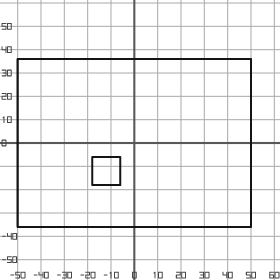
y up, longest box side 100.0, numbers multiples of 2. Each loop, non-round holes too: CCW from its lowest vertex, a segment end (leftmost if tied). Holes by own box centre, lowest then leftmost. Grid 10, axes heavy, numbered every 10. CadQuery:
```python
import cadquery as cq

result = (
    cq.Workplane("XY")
    .moveTo(-50.0, -36.0)
    .lineTo(50.0, -36.0)
    .lineTo(50.0, 36.0)
    .lineTo(-50.0, 36.0)
    .close()
    .moveTo(-18.0, -18.0)
    .lineTo(-6.0, -18.0)
    .lineTo(-6.0, -6.0)
    .lineTo(-18.0, -6.0)
    .close()
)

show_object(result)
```